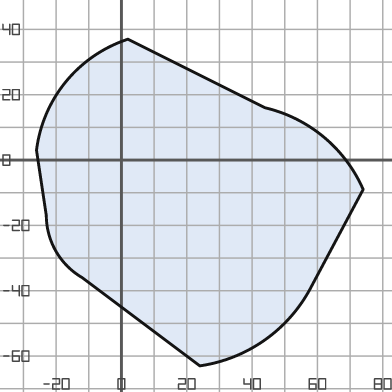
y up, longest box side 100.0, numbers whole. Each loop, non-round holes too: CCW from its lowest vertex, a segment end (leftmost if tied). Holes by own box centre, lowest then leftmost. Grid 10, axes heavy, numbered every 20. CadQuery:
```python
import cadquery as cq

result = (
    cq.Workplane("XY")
    .moveTo(24.0, -63.0)
    .threePointArc((44.0, -55.0), (58.0, -39.0))
    .lineTo(74.0, -9.0)
    .threePointArc((62.0, 7.0), (44.0, 16.0))
    .lineTo(2.0, 37.0)
    .threePointArc((-17.0, 24.0), (-26.0, 3.0))
    .lineTo(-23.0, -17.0)
    .threePointArc((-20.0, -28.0), (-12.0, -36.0))
    .close()
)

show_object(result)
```